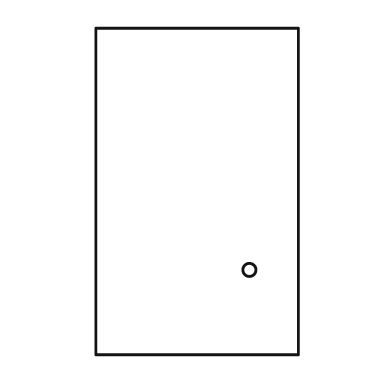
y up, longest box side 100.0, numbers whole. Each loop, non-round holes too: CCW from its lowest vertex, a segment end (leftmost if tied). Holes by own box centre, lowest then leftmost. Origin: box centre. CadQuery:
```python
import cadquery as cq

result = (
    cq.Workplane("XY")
    .moveTo(-31.0, -50.0)
    .lineTo(31.0, -50.0)
    .lineTo(31.0, 50.0)
    .lineTo(-31.0, 50.0)
    .close()
    .moveTo(16.0, -24.0)
    .circle(2.0)
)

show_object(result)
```